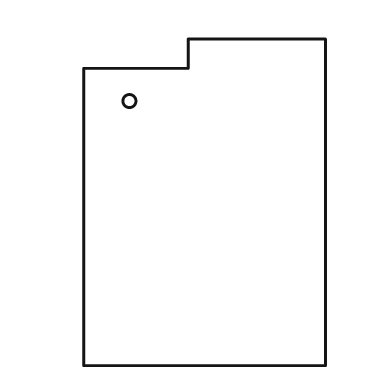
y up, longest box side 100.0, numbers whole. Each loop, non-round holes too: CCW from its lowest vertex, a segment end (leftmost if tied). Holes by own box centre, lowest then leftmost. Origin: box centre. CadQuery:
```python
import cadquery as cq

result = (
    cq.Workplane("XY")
    .moveTo(-37.0, -50.0)
    .lineTo(37.0, -50.0)
    .lineTo(37.0, 50.0)
    .lineTo(-5.0, 50.0)
    .lineTo(-5.0, 41.0)
    .lineTo(-37.0, 41.0)
    .close()
    .moveTo(-23.0, 31.0)
    .circle(2.0)
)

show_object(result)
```